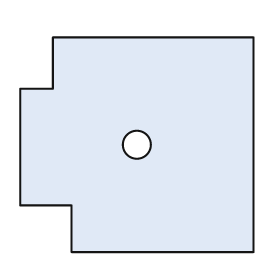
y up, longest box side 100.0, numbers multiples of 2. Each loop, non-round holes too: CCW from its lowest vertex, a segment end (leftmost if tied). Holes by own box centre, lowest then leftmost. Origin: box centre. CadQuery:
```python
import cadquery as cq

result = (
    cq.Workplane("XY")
    .moveTo(-28.0, -46.0)
    .lineTo(50.0, -46.0)
    .lineTo(50.0, 46.0)
    .lineTo(-36.0, 46.0)
    .lineTo(-36.0, 24.0)
    .lineTo(-50.0, 24.0)
    .lineTo(-50.0, -26.0)
    .lineTo(-28.0, -26.0)
    .close()
    .moveTo(0.0, 0.0)
    .circle(6.0)
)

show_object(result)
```